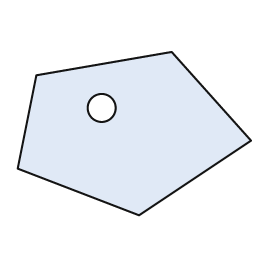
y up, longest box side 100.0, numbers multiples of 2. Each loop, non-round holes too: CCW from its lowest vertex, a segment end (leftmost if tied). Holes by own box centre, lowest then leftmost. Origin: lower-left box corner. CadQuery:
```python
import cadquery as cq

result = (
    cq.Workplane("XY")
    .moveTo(52.0, 0.0)
    .lineTo(100.0, 32.0)
    .lineTo(66.0, 70.0)
    .lineTo(8.0, 60.0)
    .lineTo(0.0, 20.0)
    .close()
    .moveTo(36.0, 46.0)
    .circle(6.0)
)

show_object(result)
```